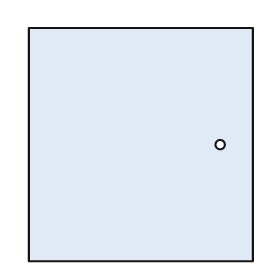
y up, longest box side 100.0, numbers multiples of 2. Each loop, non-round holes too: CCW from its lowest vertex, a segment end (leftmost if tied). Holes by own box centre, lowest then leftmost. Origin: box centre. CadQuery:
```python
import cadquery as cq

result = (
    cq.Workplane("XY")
    .moveTo(-48.0, -50.0)
    .lineTo(48.0, -50.0)
    .lineTo(48.0, 50.0)
    .lineTo(-48.0, 50.0)
    .close()
    .moveTo(34.0, 0.0)
    .circle(2.0)
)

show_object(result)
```